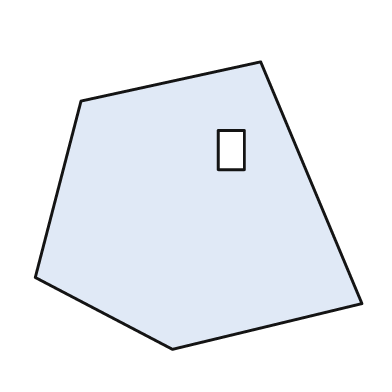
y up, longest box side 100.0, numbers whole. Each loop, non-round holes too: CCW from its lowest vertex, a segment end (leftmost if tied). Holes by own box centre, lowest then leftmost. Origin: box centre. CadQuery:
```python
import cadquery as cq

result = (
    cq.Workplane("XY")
    .moveTo(-8.0, -44.0)
    .lineTo(50.0, -30.0)
    .lineTo(19.0, 44.0)
    .lineTo(-36.0, 32.0)
    .lineTo(-50.0, -22.0)
    .close()
    .moveTo(6.0, 11.0)
    .lineTo(14.0, 11.0)
    .lineTo(14.0, 23.0)
    .lineTo(6.0, 23.0)
    .close()
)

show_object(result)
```